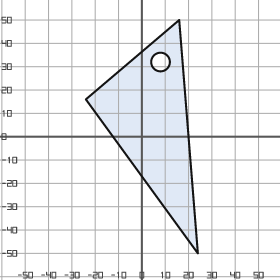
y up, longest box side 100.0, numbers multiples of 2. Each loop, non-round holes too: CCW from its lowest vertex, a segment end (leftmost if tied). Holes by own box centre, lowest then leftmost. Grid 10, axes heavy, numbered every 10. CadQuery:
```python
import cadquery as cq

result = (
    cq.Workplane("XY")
    .moveTo(24.0, -50.0)
    .lineTo(16.0, 50.0)
    .lineTo(-24.0, 16.0)
    .close()
    .moveTo(8.0, 32.0)
    .circle(4.0)
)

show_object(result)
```